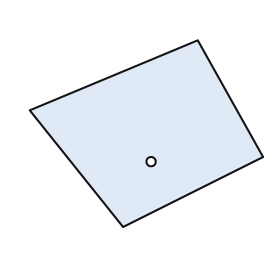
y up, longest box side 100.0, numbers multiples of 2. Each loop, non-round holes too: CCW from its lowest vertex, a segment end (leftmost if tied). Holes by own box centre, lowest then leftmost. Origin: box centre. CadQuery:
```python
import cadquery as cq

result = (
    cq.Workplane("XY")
    .moveTo(-10.0, -40.0)
    .lineTo(50.0, -10.0)
    .lineTo(22.0, 40.0)
    .lineTo(-50.0, 10.0)
    .close()
    .moveTo(2.0, -12.0)
    .circle(2.0)
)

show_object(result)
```